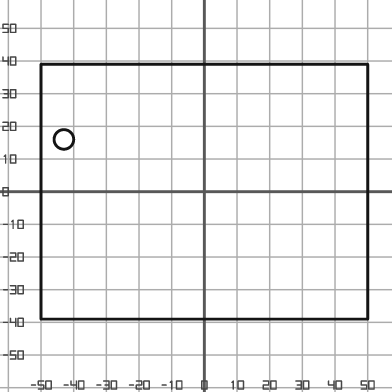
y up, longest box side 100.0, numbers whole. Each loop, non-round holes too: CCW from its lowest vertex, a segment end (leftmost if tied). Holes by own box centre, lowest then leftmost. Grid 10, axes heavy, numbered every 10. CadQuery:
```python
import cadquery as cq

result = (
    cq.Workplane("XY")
    .moveTo(-50.0, -39.0)
    .lineTo(50.0, -39.0)
    .lineTo(50.0, 39.0)
    .lineTo(-50.0, 39.0)
    .close()
    .moveTo(-43.0, 16.0)
    .circle(3.0)
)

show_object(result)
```